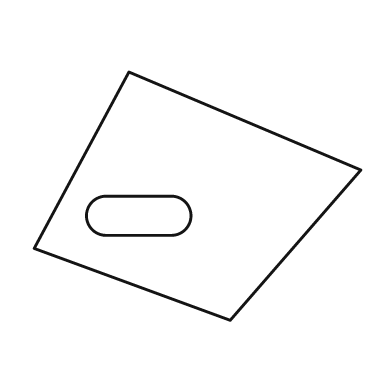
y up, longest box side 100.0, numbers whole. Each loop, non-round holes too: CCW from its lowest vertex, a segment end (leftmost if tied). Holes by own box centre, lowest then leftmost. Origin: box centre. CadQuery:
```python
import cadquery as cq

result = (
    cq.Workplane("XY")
    .moveTo(10.0, -38.0)
    .lineTo(50.0, 8.0)
    .lineTo(-21.0, 38.0)
    .lineTo(-50.0, -16.0)
    .close()
    .moveTo(-28.0, -12.0)
    .lineTo(-8.0, -12.0)
    .threePointArc((-2.0, -6.0), (-8.0, 0.0))
    .lineTo(-28.0, 0.0)
    .threePointArc((-34.0, -6.0), (-28.0, -12.0))
    .close()
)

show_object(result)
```